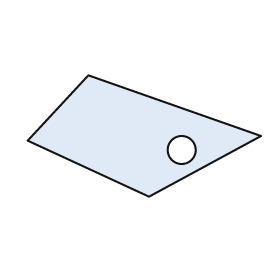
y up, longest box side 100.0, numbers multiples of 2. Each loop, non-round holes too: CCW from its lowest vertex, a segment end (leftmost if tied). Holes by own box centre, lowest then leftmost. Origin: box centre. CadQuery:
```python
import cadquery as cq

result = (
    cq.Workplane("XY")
    .moveTo(2.0, -26.0)
    .lineTo(50.0, 0.0)
    .lineTo(-24.0, 26.0)
    .lineTo(-50.0, -2.0)
    .close()
    .moveTo(16.0, -6.0)
    .circle(6.0)
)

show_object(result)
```